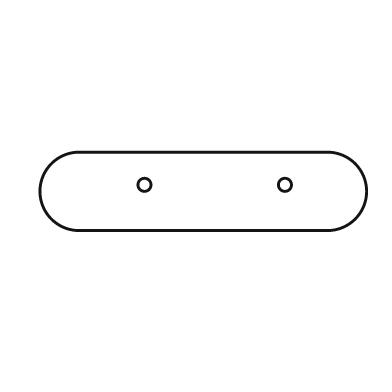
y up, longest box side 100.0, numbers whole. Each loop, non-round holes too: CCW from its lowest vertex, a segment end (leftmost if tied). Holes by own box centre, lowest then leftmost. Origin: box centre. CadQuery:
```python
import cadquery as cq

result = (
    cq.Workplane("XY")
    .moveTo(-38.0, -12.0)
    .lineTo(38.0, -12.0)
    .threePointArc((50.0, 0.0), (38.0, 12.0))
    .lineTo(-38.0, 12.0)
    .threePointArc((-50.0, 0.0), (-38.0, -12.0))
    .close()
    .moveTo(-18.0, 2.0)
    .circle(2.0)
    .moveTo(25.0, 2.0)
    .circle(2.0)
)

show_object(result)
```